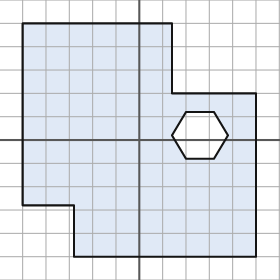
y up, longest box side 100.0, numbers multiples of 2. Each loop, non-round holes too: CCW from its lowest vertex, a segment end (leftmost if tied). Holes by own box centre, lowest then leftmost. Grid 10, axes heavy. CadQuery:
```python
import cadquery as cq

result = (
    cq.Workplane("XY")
    .moveTo(-28.0, -50.0)
    .lineTo(50.0, -50.0)
    .lineTo(50.0, 20.0)
    .lineTo(14.0, 20.0)
    .lineTo(14.0, 50.0)
    .lineTo(-50.0, 50.0)
    .lineTo(-50.0, -28.0)
    .lineTo(-28.0, -28.0)
    .close()
    .moveTo(20.0, -8.0)
    .lineTo(32.0, -8.0)
    .lineTo(38.0, 2.0)
    .lineTo(32.0, 12.0)
    .lineTo(20.0, 12.0)
    .lineTo(14.0, 2.0)
    .close()
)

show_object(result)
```